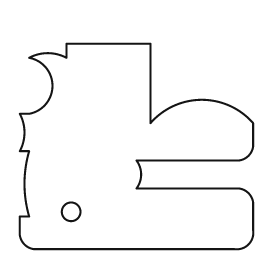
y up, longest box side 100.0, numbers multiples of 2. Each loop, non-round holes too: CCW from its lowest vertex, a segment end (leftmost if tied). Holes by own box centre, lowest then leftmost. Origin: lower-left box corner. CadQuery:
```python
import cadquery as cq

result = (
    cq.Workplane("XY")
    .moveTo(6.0, 0.0)
    .lineTo(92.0, 0.0)
    .threePointArc((98.0, 2.0), (100.0, 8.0))
    .lineTo(100.0, 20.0)
    .threePointArc((98.0, 24.0), (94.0, 26.0))
    .lineTo(50.0, 26.0)
    .threePointArc((52.0, 32.0), (50.0, 38.0))
    .lineTo(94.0, 38.0)
    .threePointArc((98.0, 40.0), (100.0, 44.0))
    .lineTo(100.0, 54.0)
    .threePointArc((78.0, 64.0), (56.0, 54.0))
    .lineTo(56.0, 88.0)
    .lineTo(20.0, 88.0)
    .lineTo(20.0, 82.0)
    .threePointArc((12.0, 84.0), (4.0, 82.0))
    .threePointArc((14.0, 70.0), (4.0, 58.0))
    .lineTo(0.0, 58.0)
    .threePointArc((2.0, 50.0), (0.0, 42.0))
    .lineTo(4.0, 42.0)
    .threePointArc((2.0, 28.0), (4.0, 14.0))
    .lineTo(0.0, 14.0)
    .lineTo(0.0, 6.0)
    .threePointArc((2.0, 2.0), (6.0, 0.0))
    .close()
    .moveTo(22.0, 16.0)
    .circle(4.0)
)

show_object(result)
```